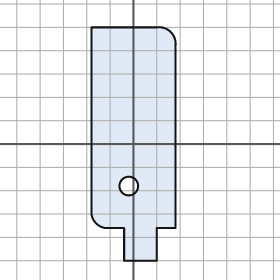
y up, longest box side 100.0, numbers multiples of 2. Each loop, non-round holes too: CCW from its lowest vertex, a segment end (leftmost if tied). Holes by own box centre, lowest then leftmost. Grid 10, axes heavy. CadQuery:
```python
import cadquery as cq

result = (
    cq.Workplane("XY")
    .moveTo(-4.0, -50.0)
    .lineTo(10.0, -50.0)
    .lineTo(10.0, -36.0)
    .lineTo(18.0, -36.0)
    .lineTo(18.0, 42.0)
    .threePointArc((16.0, 48.0), (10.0, 50.0))
    .lineTo(-18.0, 50.0)
    .lineTo(-18.0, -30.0)
    .threePointArc((-16.0, -34.0), (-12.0, -36.0))
    .lineTo(-4.0, -36.0)
    .close()
    .moveTo(-2.0, -18.0)
    .circle(4.0)
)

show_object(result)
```